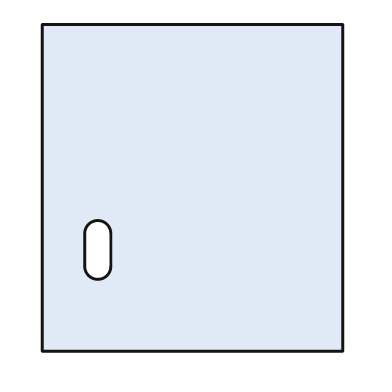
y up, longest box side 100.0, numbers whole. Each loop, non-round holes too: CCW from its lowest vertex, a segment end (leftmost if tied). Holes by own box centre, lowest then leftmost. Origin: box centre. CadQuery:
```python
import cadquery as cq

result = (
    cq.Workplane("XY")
    .moveTo(-46.0, -50.0)
    .lineTo(46.0, -50.0)
    .lineTo(46.0, 50.0)
    .lineTo(-46.0, 50.0)
    .close()
    .moveTo(-33.0, -24.0)
    .threePointArc((-29.0, -28.0), (-25.0, -24.0))
    .lineTo(-25.0, -14.0)
    .threePointArc((-29.0, -10.0), (-33.0, -14.0))
    .close()
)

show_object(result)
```